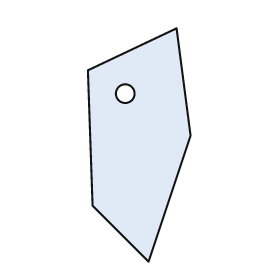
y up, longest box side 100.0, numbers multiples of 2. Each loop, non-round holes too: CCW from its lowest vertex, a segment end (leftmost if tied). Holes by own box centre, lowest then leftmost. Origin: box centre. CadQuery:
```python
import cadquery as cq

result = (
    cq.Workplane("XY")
    .moveTo(4.0, -50.0)
    .lineTo(22.0, 4.0)
    .lineTo(16.0, 50.0)
    .lineTo(-22.0, 32.0)
    .lineTo(-20.0, -26.0)
    .close()
    .moveTo(-6.0, 22.0)
    .circle(4.0)
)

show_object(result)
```